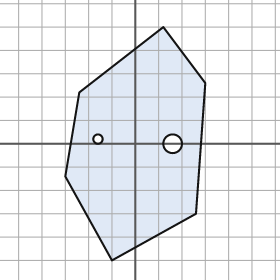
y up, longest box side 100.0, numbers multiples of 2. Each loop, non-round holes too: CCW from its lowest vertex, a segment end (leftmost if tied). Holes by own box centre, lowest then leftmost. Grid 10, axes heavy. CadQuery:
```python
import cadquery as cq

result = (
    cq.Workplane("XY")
    .moveTo(-10.0, -50.0)
    .lineTo(26.0, -30.0)
    .lineTo(30.0, 26.0)
    .lineTo(12.0, 50.0)
    .lineTo(-24.0, 22.0)
    .lineTo(-30.0, -14.0)
    .close()
    .moveTo(16.0, 0.0)
    .circle(4.0)
    .moveTo(-16.0, 2.0)
    .circle(2.0)
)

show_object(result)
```